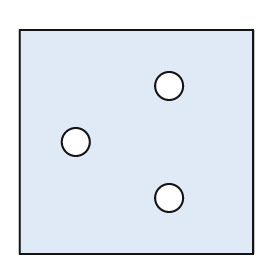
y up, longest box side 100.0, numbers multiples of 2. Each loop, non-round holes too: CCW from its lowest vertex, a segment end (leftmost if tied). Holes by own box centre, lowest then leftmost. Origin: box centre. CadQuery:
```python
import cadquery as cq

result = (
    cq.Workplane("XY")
    .moveTo(-50.0, -48.0)
    .lineTo(50.0, -48.0)
    .lineTo(50.0, 48.0)
    .lineTo(-50.0, 48.0)
    .close()
    .moveTo(14.0, -24.0)
    .circle(6.0)
    .moveTo(-26.0, 0.0)
    .circle(6.0)
    .moveTo(14.0, 24.0)
    .circle(6.0)
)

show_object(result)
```